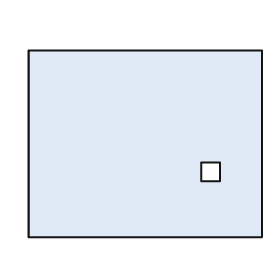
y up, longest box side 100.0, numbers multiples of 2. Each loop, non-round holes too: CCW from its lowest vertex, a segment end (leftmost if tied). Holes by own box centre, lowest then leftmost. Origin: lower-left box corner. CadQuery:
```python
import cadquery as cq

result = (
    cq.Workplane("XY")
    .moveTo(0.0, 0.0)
    .lineTo(100.0, 0.0)
    .lineTo(100.0, 80.0)
    .lineTo(0.0, 80.0)
    .close()
    .moveTo(74.0, 24.0)
    .lineTo(82.0, 24.0)
    .lineTo(82.0, 32.0)
    .lineTo(74.0, 32.0)
    .close()
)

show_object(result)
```